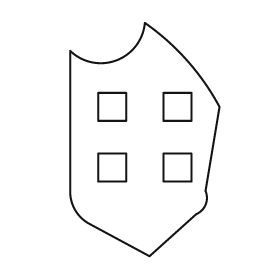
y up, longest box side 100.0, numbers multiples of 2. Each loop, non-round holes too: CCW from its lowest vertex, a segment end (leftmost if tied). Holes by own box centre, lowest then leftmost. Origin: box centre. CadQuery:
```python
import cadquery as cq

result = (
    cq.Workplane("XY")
    .moveTo(2.0, -50.0)
    .lineTo(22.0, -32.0)
    .threePointArc((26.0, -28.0), (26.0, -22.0))
    .lineTo(32.0, 14.0)
    .threePointArc((18.0, 34.0), (0.0, 50.0))
    .threePointArc((-12.0, 34.0), (-32.0, 38.0))
    .lineTo(-32.0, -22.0)
    .threePointArc((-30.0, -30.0), (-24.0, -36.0))
    .close()
    .moveTo(-20.0, -18.0)
    .lineTo(-8.0, -18.0)
    .lineTo(-8.0, -6.0)
    .lineTo(-20.0, -6.0)
    .close()
    .moveTo(8.0, -18.0)
    .lineTo(20.0, -18.0)
    .lineTo(20.0, -6.0)
    .lineTo(8.0, -6.0)
    .close()
    .moveTo(-20.0, 8.0)
    .lineTo(-8.0, 8.0)
    .lineTo(-8.0, 20.0)
    .lineTo(-20.0, 20.0)
    .close()
    .moveTo(8.0, 8.0)
    .lineTo(20.0, 8.0)
    .lineTo(20.0, 20.0)
    .lineTo(8.0, 20.0)
    .close()
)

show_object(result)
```